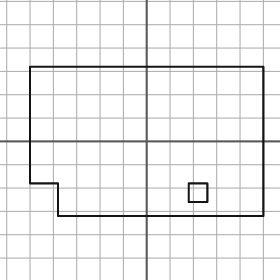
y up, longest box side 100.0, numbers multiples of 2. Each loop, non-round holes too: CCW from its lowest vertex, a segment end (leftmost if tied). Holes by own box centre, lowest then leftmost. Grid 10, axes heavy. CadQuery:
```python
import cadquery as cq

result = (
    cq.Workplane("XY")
    .moveTo(-38.0, -32.0)
    .lineTo(50.0, -32.0)
    .lineTo(50.0, 32.0)
    .lineTo(-50.0, 32.0)
    .lineTo(-50.0, -18.0)
    .lineTo(-38.0, -18.0)
    .close()
    .moveTo(18.0, -26.0)
    .lineTo(26.0, -26.0)
    .lineTo(26.0, -18.0)
    .lineTo(18.0, -18.0)
    .close()
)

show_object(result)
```